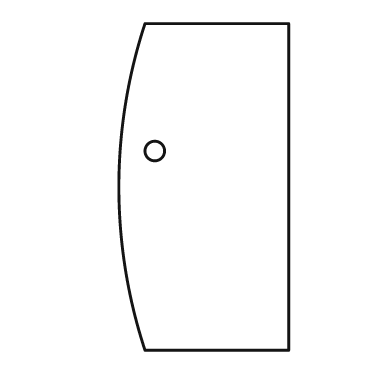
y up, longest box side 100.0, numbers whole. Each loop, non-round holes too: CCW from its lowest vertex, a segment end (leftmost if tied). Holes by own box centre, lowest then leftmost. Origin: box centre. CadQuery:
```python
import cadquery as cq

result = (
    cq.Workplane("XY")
    .moveTo(-18.0, -50.0)
    .lineTo(26.0, -50.0)
    .lineTo(26.0, 50.0)
    .lineTo(-18.0, 50.0)
    .threePointArc((-26.0, 0.0), (-18.0, -50.0))
    .close()
    .moveTo(-15.0, 11.0)
    .circle(3.0)
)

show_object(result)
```